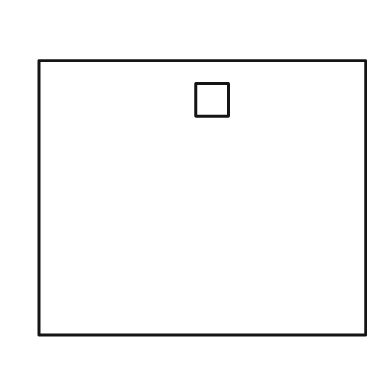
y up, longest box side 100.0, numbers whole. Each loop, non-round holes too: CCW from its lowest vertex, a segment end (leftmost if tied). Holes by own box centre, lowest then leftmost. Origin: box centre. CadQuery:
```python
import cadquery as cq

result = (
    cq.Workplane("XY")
    .moveTo(-50.0, -42.0)
    .lineTo(50.0, -42.0)
    .lineTo(50.0, 42.0)
    .lineTo(-50.0, 42.0)
    .close()
    .moveTo(-2.0, 25.0)
    .lineTo(8.0, 25.0)
    .lineTo(8.0, 35.0)
    .lineTo(-2.0, 35.0)
    .close()
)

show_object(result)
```